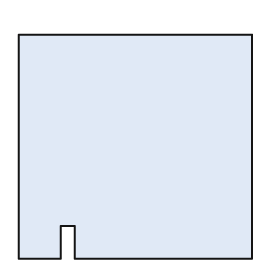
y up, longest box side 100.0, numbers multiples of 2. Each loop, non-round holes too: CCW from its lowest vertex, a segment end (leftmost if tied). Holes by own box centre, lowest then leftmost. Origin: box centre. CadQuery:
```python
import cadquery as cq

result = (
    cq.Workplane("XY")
    .moveTo(-50.0, -48.0)
    .lineTo(-32.0, -48.0)
    .lineTo(-32.0, -34.0)
    .lineTo(-26.0, -34.0)
    .lineTo(-26.0, -48.0)
    .lineTo(50.0, -48.0)
    .lineTo(50.0, 48.0)
    .lineTo(-50.0, 48.0)
    .close()
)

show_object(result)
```